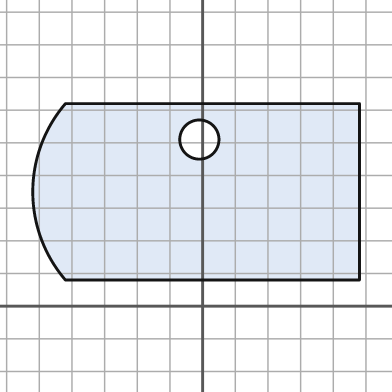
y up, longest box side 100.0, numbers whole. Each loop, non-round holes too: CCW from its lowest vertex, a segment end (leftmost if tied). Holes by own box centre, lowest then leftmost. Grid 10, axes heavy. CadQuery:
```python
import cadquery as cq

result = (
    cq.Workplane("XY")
    .moveTo(-42.0, 8.0)
    .lineTo(48.0, 8.0)
    .lineTo(48.0, 62.0)
    .lineTo(-42.0, 62.0)
    .threePointArc((-52.0, 35.0), (-42.0, 8.0))
    .close()
    .moveTo(-1.0, 51.0)
    .circle(6.0)
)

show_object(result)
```